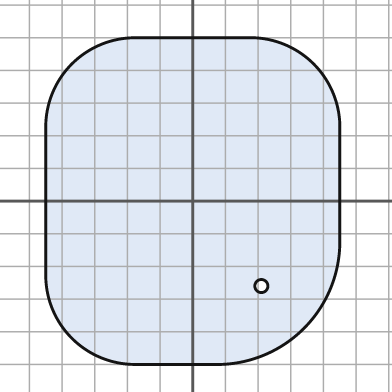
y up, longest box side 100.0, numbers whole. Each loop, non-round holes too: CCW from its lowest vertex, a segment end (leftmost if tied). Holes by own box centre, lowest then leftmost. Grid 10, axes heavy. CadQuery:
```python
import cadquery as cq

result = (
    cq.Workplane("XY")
    .moveTo(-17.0, -50.0)
    .lineTo(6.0, -50.0)
    .threePointArc((34.0, -39.0), (45.0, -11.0))
    .lineTo(45.0, 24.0)
    .threePointArc((37.0, 42.0), (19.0, 50.0))
    .lineTo(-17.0, 50.0)
    .threePointArc((-37.0, 42.0), (-45.0, 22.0))
    .lineTo(-45.0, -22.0)
    .threePointArc((-37.0, -42.0), (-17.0, -50.0))
    .close()
    .moveTo(21.0, -26.0)
    .circle(2.0)
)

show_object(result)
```